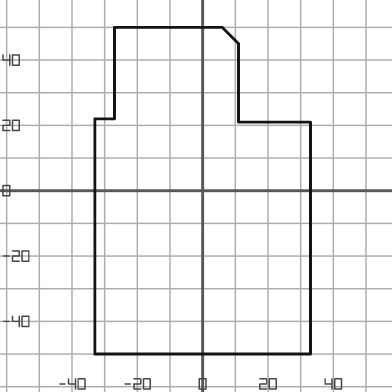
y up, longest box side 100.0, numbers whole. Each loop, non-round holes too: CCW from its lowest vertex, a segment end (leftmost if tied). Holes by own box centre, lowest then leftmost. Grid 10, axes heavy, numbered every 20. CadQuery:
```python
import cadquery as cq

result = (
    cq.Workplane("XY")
    .moveTo(-33.0, -50.0)
    .lineTo(33.0, -50.0)
    .lineTo(33.0, 21.0)
    .lineTo(11.0, 21.0)
    .lineTo(11.0, 45.0)
    .lineTo(6.0, 50.0)
    .lineTo(-27.0, 50.0)
    .lineTo(-27.0, 22.0)
    .lineTo(-33.0, 22.0)
    .close()
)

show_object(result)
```